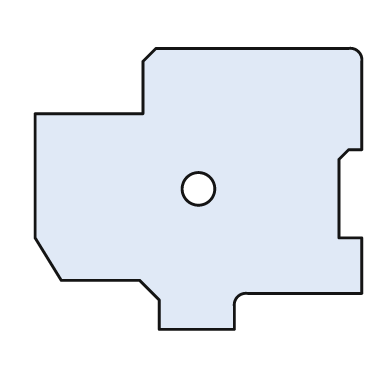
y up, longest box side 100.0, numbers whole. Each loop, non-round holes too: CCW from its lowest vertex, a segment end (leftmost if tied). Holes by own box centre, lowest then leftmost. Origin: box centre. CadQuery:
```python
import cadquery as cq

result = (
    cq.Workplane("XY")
    .moveTo(-12.0, -43.0)
    .lineTo(11.0, -43.0)
    .lineTo(11.0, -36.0)
    .threePointArc((12.0, -33.0), (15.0, -32.0))
    .lineTo(50.0, -32.0)
    .lineTo(50.0, -15.0)
    .lineTo(43.0, -15.0)
    .lineTo(43.0, 9.0)
    .lineTo(46.0, 12.0)
    .lineTo(50.0, 12.0)
    .lineTo(50.0, 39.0)
    .threePointArc((49.0, 42.0), (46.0, 43.0))
    .lineTo(-13.0, 43.0)
    .lineTo(-17.0, 39.0)
    .lineTo(-17.0, 23.0)
    .lineTo(-50.0, 23.0)
    .lineTo(-50.0, -15.0)
    .lineTo(-42.0, -28.0)
    .lineTo(-18.0, -28.0)
    .lineTo(-12.0, -34.0)
    .close()
    .moveTo(0.0, 0.0)
    .circle(5.0)
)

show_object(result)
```